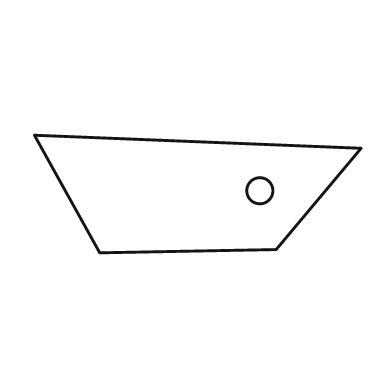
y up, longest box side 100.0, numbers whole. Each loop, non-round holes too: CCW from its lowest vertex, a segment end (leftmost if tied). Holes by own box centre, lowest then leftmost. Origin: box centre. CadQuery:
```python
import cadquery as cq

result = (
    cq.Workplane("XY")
    .moveTo(-30.0, -18.0)
    .lineTo(24.0, -17.0)
    .lineTo(50.0, 14.0)
    .lineTo(-50.0, 18.0)
    .close()
    .moveTo(19.0, 1.0)
    .circle(4.0)
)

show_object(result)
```